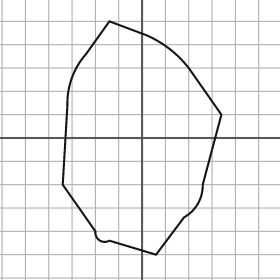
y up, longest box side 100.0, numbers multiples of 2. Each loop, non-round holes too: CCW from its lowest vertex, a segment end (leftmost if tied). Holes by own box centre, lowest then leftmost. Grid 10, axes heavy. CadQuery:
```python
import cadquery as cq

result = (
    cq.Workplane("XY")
    .moveTo(6.0, -50.0)
    .lineTo(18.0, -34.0)
    .threePointArc((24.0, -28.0), (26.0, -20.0))
    .lineTo(34.0, 10.0)
    .lineTo(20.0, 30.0)
    .threePointArc((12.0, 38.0), (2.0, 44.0))
    .lineTo(-14.0, 50.0)
    .lineTo(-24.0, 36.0)
    .threePointArc((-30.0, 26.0), (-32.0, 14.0))
    .lineTo(-34.0, -20.0)
    .lineTo(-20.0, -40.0)
    .threePointArc((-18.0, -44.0), (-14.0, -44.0))
    .close()
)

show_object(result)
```